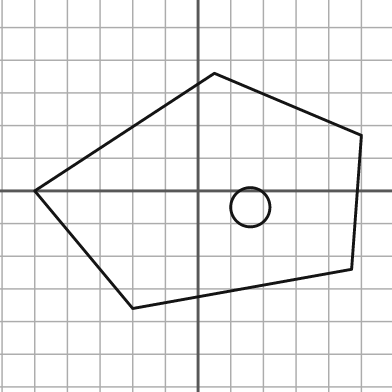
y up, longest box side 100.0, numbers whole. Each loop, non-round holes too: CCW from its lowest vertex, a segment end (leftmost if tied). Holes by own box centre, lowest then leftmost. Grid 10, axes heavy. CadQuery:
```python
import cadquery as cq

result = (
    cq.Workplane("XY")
    .moveTo(-20.0, -36.0)
    .lineTo(47.0, -24.0)
    .lineTo(50.0, 17.0)
    .lineTo(5.0, 36.0)
    .lineTo(-50.0, 0.0)
    .close()
    .moveTo(16.0, -5.0)
    .circle(6.0)
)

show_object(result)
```